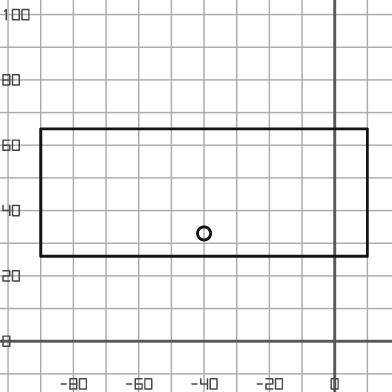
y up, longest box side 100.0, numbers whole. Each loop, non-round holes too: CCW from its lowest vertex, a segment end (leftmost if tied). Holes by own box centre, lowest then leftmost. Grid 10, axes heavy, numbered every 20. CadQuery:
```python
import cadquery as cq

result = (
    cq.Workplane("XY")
    .moveTo(-90.0, 26.0)
    .lineTo(10.0, 26.0)
    .lineTo(10.0, 65.0)
    .lineTo(-90.0, 65.0)
    .close()
    .moveTo(-40.0, 33.0)
    .circle(2.0)
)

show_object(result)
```